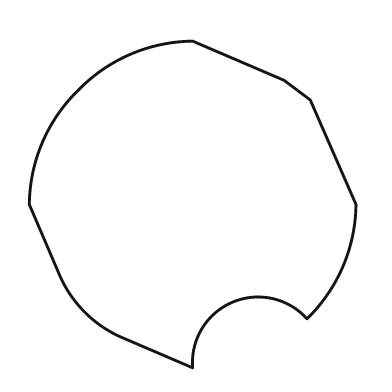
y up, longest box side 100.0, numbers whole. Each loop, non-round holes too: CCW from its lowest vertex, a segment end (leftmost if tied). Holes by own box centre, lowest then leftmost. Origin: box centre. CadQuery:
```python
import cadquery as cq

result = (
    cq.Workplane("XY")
    .moveTo(0.0, -50.0)
    .threePointArc((12.0, -30.0), (35.0, -35.0))
    .threePointArc((46.0, -19.0), (50.0, 0.0))
    .lineTo(36.0, 32.0)
    .lineTo(28.0, 38.0)
    .lineTo(0.0, 50.0)
    .threePointArc((-19.0, 46.0), (-35.0, 35.0))
    .threePointArc((-46.0, 19.0), (-50.0, 0.0))
    .lineTo(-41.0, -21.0)
    .threePointArc((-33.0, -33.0), (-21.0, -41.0))
    .close()
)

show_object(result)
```